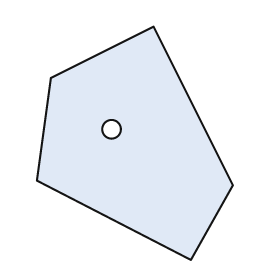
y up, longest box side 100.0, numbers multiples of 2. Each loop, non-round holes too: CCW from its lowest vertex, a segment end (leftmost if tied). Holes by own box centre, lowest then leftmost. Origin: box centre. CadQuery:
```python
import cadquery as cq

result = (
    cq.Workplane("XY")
    .moveTo(24.0, -50.0)
    .lineTo(42.0, -18.0)
    .lineTo(8.0, 50.0)
    .lineTo(-36.0, 28.0)
    .lineTo(-42.0, -16.0)
    .close()
    .moveTo(-10.0, 6.0)
    .circle(4.0)
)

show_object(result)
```